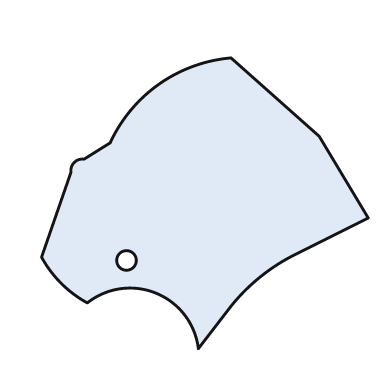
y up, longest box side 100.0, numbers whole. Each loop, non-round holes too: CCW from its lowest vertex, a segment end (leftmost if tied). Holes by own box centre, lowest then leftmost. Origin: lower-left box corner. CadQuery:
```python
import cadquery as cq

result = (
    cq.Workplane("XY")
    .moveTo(48.0, 0.0)
    .lineTo(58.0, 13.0)
    .threePointArc((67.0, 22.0), (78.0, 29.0))
    .lineTo(100.0, 40.0)
    .lineTo(85.0, 65.0)
    .lineTo(58.0, 89.0)
    .threePointArc((36.0, 81.0), (21.0, 63.0))
    .lineTo(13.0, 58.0)
    .threePointArc((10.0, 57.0), (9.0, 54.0))
    .lineTo(0.0, 28.0)
    .threePointArc((6.0, 20.0), (14.0, 14.0))
    .threePointArc((35.0, 17.0), (48.0, 0.0))
    .close()
    .moveTo(26.0, 27.0)
    .circle(3.0)
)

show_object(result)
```